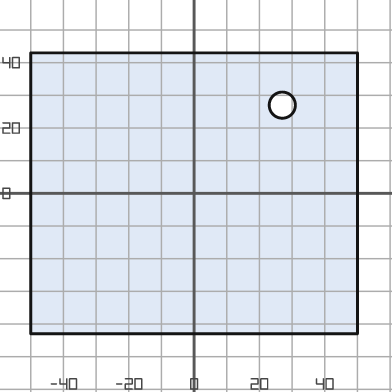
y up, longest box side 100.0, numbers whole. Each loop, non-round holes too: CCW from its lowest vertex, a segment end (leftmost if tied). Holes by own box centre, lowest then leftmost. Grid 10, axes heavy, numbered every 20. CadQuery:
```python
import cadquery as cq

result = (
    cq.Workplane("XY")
    .moveTo(-50.0, -43.0)
    .lineTo(50.0, -43.0)
    .lineTo(50.0, 43.0)
    .lineTo(-50.0, 43.0)
    .close()
    .moveTo(27.0, 27.0)
    .circle(4.0)
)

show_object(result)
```